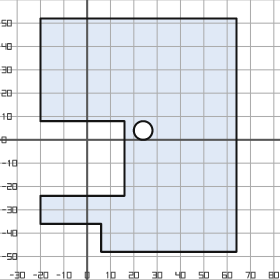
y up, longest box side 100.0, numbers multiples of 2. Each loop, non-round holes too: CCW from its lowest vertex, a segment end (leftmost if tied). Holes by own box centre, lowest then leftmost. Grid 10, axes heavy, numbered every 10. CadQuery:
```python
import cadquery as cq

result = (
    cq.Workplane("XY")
    .moveTo(6.0, -48.0)
    .lineTo(64.0, -48.0)
    .lineTo(64.0, 52.0)
    .lineTo(-20.0, 52.0)
    .lineTo(-20.0, 8.0)
    .lineTo(16.0, 8.0)
    .lineTo(16.0, -24.0)
    .lineTo(-20.0, -24.0)
    .lineTo(-20.0, -36.0)
    .lineTo(6.0, -36.0)
    .close()
    .moveTo(24.0, 4.0)
    .circle(4.0)
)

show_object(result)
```